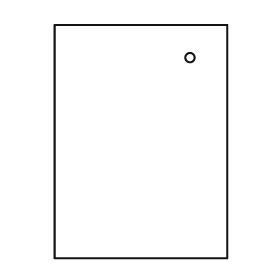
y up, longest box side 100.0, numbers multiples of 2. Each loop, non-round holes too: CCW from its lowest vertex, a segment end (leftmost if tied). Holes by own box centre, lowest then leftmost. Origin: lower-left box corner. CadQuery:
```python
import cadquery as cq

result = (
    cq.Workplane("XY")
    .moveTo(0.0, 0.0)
    .lineTo(74.0, 0.0)
    .lineTo(74.0, 100.0)
    .lineTo(0.0, 100.0)
    .close()
    .moveTo(58.0, 86.0)
    .circle(2.0)
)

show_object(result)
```